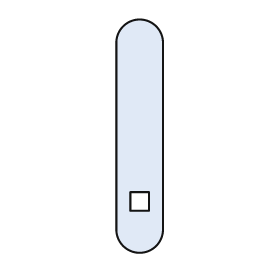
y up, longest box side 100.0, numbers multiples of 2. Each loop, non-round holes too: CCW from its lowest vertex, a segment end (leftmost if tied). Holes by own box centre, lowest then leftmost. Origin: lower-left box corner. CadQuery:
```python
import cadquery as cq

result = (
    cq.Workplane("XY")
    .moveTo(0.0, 10.0)
    .threePointArc((10.0, 0.0), (20.0, 10.0))
    .lineTo(20.0, 90.0)
    .threePointArc((10.0, 100.0), (0.0, 90.0))
    .close()
    .moveTo(6.0, 18.0)
    .lineTo(14.0, 18.0)
    .lineTo(14.0, 26.0)
    .lineTo(6.0, 26.0)
    .close()
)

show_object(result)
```